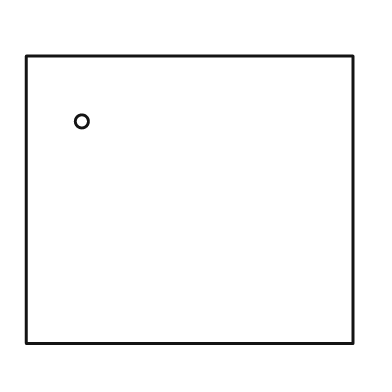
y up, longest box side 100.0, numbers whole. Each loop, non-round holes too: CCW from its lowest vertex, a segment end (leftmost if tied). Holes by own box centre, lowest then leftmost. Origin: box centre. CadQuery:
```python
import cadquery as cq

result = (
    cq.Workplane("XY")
    .moveTo(-50.0, -44.0)
    .lineTo(50.0, -44.0)
    .lineTo(50.0, 44.0)
    .lineTo(-50.0, 44.0)
    .close()
    .moveTo(-33.0, 24.0)
    .circle(2.0)
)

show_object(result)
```